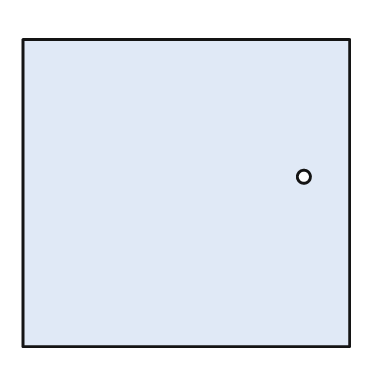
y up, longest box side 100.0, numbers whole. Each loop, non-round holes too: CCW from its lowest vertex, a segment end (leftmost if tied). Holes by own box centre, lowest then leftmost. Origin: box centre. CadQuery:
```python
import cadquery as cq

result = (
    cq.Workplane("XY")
    .moveTo(-50.0, -47.0)
    .lineTo(50.0, -47.0)
    .lineTo(50.0, 47.0)
    .lineTo(-50.0, 47.0)
    .close()
    .moveTo(36.0, 5.0)
    .circle(2.0)
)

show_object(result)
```